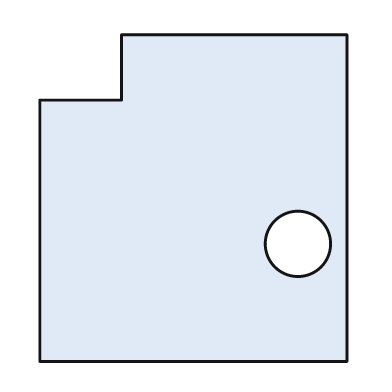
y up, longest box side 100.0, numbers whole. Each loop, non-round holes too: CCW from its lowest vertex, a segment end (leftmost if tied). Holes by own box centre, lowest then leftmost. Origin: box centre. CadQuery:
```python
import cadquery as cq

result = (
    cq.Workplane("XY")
    .moveTo(-47.0, -50.0)
    .lineTo(47.0, -50.0)
    .lineTo(47.0, 50.0)
    .lineTo(-22.0, 50.0)
    .lineTo(-22.0, 30.0)
    .lineTo(-47.0, 30.0)
    .close()
    .moveTo(32.0, -14.0)
    .circle(10.0)
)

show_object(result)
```